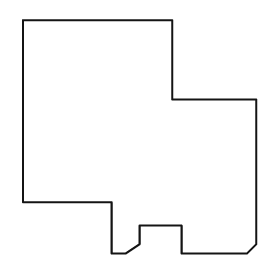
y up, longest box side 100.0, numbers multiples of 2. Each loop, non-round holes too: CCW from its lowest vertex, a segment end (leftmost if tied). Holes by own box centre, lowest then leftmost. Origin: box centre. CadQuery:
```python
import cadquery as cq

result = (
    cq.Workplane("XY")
    .moveTo(-12.0, -50.0)
    .lineTo(-6.0, -50.0)
    .lineTo(0.0, -46.0)
    .lineTo(0.0, -38.0)
    .lineTo(18.0, -38.0)
    .lineTo(18.0, -50.0)
    .lineTo(46.0, -50.0)
    .lineTo(50.0, -46.0)
    .lineTo(50.0, 16.0)
    .lineTo(14.0, 16.0)
    .lineTo(14.0, 50.0)
    .lineTo(-50.0, 50.0)
    .lineTo(-50.0, -28.0)
    .lineTo(-12.0, -28.0)
    .close()
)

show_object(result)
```